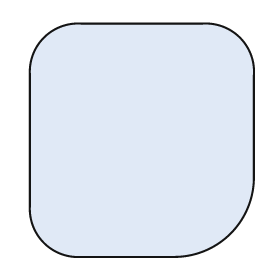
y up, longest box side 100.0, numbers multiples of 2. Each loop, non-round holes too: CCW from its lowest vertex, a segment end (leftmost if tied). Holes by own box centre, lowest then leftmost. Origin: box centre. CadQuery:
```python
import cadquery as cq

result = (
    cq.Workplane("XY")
    .moveTo(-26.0, -50.0)
    .lineTo(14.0, -50.0)
    .threePointArc((38.0, -40.0), (48.0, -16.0))
    .lineTo(48.0, 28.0)
    .threePointArc((42.0, 44.0), (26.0, 50.0))
    .lineTo(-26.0, 50.0)
    .threePointArc((-42.0, 44.0), (-48.0, 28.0))
    .lineTo(-48.0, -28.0)
    .threePointArc((-42.0, -44.0), (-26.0, -50.0))
    .close()
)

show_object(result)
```